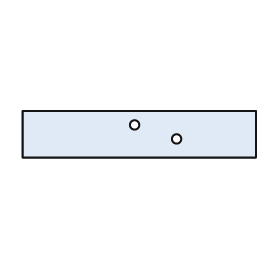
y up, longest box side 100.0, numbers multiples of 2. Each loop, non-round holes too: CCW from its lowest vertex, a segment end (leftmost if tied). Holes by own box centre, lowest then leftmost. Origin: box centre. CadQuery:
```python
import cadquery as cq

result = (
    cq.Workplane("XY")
    .moveTo(-50.0, -10.0)
    .lineTo(50.0, -10.0)
    .lineTo(50.0, 10.0)
    .lineTo(-50.0, 10.0)
    .close()
    .moveTo(16.0, -2.0)
    .circle(2.0)
    .moveTo(-2.0, 4.0)
    .circle(2.0)
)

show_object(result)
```